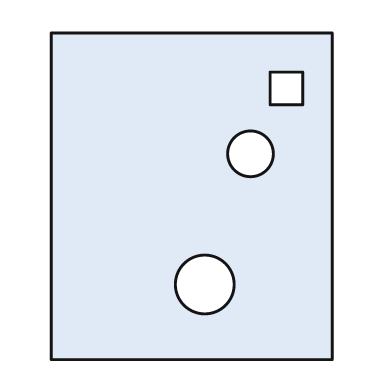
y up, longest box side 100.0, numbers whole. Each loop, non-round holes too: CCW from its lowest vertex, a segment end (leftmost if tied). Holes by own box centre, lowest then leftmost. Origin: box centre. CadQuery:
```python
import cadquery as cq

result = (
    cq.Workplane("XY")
    .moveTo(-43.0, -50.0)
    .lineTo(43.0, -50.0)
    .lineTo(43.0, 50.0)
    .lineTo(-43.0, 50.0)
    .close()
    .moveTo(4.0, -27.0)
    .circle(9.0)
    .moveTo(18.0, 13.0)
    .circle(7.0)
    .moveTo(24.0, 28.0)
    .lineTo(34.0, 28.0)
    .lineTo(34.0, 38.0)
    .lineTo(24.0, 38.0)
    .close()
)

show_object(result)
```